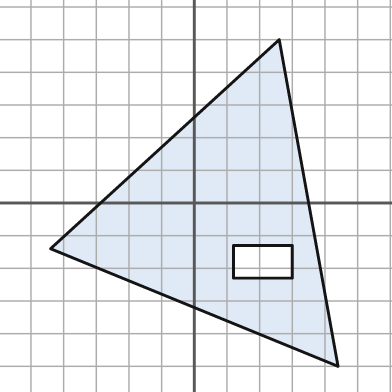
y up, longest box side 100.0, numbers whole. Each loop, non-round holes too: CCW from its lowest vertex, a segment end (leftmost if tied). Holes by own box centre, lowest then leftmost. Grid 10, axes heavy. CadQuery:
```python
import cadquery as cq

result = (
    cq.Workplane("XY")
    .moveTo(44.0, -50.0)
    .lineTo(26.0, 50.0)
    .lineTo(-44.0, -14.0)
    .close()
    .moveTo(12.0, -23.0)
    .lineTo(30.0, -23.0)
    .lineTo(30.0, -13.0)
    .lineTo(12.0, -13.0)
    .close()
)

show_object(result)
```